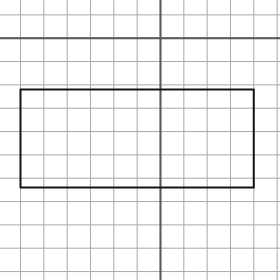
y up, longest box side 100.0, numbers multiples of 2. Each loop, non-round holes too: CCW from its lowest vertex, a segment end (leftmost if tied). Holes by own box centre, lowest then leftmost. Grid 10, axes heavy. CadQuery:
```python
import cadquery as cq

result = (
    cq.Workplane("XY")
    .moveTo(-60.0, -64.0)
    .lineTo(40.0, -64.0)
    .lineTo(40.0, -22.0)
    .lineTo(-60.0, -22.0)
    .close()
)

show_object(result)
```